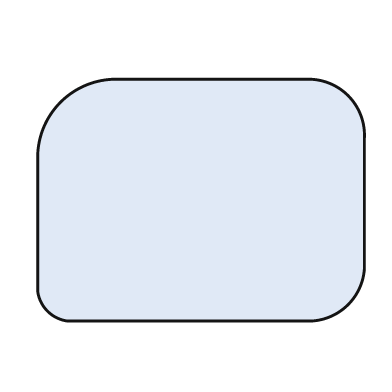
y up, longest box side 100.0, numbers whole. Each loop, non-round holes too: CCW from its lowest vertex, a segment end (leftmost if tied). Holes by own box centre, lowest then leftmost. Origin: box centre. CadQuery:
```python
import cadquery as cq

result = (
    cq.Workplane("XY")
    .moveTo(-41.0, -37.0)
    .lineTo(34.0, -37.0)
    .threePointArc((45.0, -32.0), (50.0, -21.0))
    .lineTo(50.0, 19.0)
    .threePointArc((45.0, 32.0), (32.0, 37.0))
    .lineTo(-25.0, 37.0)
    .threePointArc((-43.0, 30.0), (-50.0, 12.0))
    .lineTo(-50.0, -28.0)
    .threePointArc((-47.0, -34.0), (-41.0, -37.0))
    .close()
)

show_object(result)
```